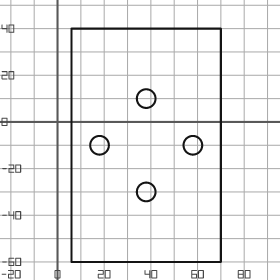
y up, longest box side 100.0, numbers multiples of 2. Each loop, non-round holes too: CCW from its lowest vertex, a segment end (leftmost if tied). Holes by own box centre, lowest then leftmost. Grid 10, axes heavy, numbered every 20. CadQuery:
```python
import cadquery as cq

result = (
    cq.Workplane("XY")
    .moveTo(6.0, -60.0)
    .lineTo(70.0, -60.0)
    .lineTo(70.0, 40.0)
    .lineTo(6.0, 40.0)
    .close()
    .moveTo(38.0, -30.0)
    .circle(4.0)
    .moveTo(18.0, -10.0)
    .circle(4.0)
    .moveTo(58.0, -10.0)
    .circle(4.0)
    .moveTo(38.0, 10.0)
    .circle(4.0)
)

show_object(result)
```